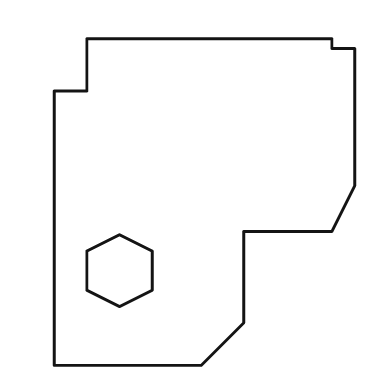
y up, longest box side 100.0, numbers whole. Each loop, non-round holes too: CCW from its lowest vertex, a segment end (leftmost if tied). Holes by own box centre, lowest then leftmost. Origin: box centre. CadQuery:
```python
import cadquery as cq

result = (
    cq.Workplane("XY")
    .moveTo(-46.0, -50.0)
    .lineTo(-1.0, -50.0)
    .lineTo(12.0, -37.0)
    .lineTo(12.0, -9.0)
    .lineTo(39.0, -9.0)
    .lineTo(46.0, 5.0)
    .lineTo(46.0, 47.0)
    .lineTo(39.0, 47.0)
    .lineTo(39.0, 50.0)
    .lineTo(-36.0, 50.0)
    .lineTo(-36.0, 34.0)
    .lineTo(-46.0, 34.0)
    .close()
    .moveTo(-26.0, -32.0)
    .lineTo(-16.0, -27.0)
    .lineTo(-16.0, -15.0)
    .lineTo(-26.0, -10.0)
    .lineTo(-36.0, -15.0)
    .lineTo(-36.0, -27.0)
    .close()
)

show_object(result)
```